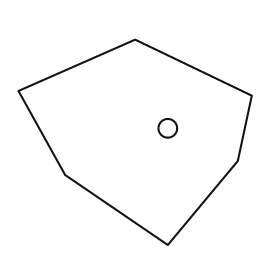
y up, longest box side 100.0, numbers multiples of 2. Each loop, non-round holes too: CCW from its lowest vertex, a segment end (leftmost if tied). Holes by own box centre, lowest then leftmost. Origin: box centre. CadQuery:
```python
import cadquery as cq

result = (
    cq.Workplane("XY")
    .moveTo(14.0, -44.0)
    .lineTo(44.0, -8.0)
    .lineTo(50.0, 20.0)
    .lineTo(0.0, 44.0)
    .lineTo(-50.0, 22.0)
    .lineTo(-30.0, -14.0)
    .close()
    .moveTo(14.0, 6.0)
    .circle(4.0)
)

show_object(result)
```